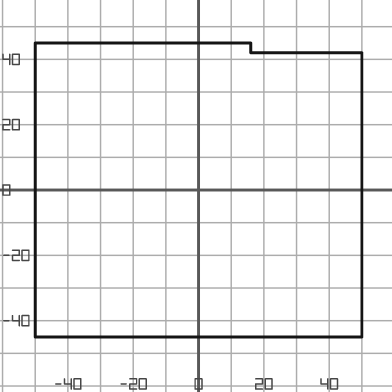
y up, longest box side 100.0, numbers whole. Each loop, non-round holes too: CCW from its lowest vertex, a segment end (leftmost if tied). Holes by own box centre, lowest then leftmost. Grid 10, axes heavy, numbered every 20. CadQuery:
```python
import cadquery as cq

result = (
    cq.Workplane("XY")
    .moveTo(-50.0, -45.0)
    .lineTo(50.0, -45.0)
    .lineTo(50.0, 42.0)
    .lineTo(16.0, 42.0)
    .lineTo(16.0, 45.0)
    .lineTo(-50.0, 45.0)
    .close()
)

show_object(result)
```